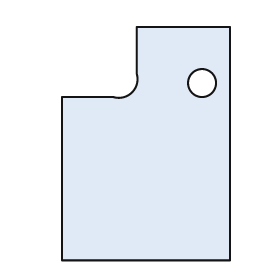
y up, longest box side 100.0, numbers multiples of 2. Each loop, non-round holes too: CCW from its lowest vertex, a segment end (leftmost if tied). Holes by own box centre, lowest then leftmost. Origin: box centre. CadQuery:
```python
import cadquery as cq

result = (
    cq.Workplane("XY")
    .moveTo(-36.0, -50.0)
    .lineTo(36.0, -50.0)
    .lineTo(36.0, 50.0)
    .lineTo(-4.0, 50.0)
    .lineTo(-4.0, 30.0)
    .threePointArc((-6.0, 22.0), (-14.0, 20.0))
    .lineTo(-36.0, 20.0)
    .close()
    .moveTo(24.0, 26.0)
    .circle(6.0)
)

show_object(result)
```